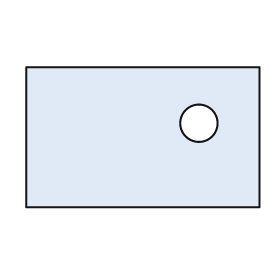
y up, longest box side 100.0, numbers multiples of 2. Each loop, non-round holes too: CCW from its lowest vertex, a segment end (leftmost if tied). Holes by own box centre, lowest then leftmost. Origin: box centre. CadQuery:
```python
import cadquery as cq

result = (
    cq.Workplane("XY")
    .moveTo(-50.0, -30.0)
    .lineTo(50.0, -30.0)
    .lineTo(50.0, 30.0)
    .lineTo(-50.0, 30.0)
    .close()
    .moveTo(24.0, 6.0)
    .circle(8.0)
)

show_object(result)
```